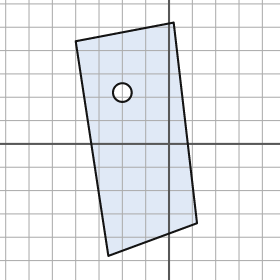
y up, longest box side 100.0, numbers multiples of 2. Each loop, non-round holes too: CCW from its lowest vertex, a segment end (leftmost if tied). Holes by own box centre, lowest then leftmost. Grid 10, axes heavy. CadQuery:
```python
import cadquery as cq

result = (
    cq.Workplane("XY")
    .moveTo(-26.0, -48.0)
    .lineTo(12.0, -34.0)
    .lineTo(2.0, 52.0)
    .lineTo(-40.0, 44.0)
    .close()
    .moveTo(-20.0, 22.0)
    .circle(4.0)
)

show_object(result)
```